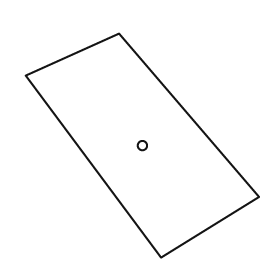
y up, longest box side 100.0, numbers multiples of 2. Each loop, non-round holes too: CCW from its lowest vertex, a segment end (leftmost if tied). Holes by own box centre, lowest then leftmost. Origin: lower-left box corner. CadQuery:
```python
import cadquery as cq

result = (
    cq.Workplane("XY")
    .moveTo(58.0, 0.0)
    .lineTo(100.0, 26.0)
    .lineTo(40.0, 96.0)
    .lineTo(0.0, 78.0)
    .close()
    .moveTo(50.0, 48.0)
    .circle(2.0)
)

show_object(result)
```